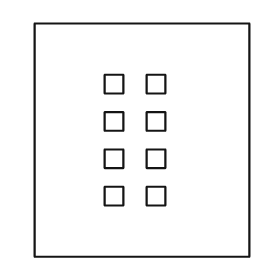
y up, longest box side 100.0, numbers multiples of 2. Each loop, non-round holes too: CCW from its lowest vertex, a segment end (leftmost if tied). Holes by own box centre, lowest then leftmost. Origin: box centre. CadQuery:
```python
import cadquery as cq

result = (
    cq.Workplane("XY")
    .moveTo(-46.0, -50.0)
    .lineTo(46.0, -50.0)
    .lineTo(46.0, 50.0)
    .lineTo(-46.0, 50.0)
    .close()
    .moveTo(-16.0, -28.0)
    .lineTo(-8.0, -28.0)
    .lineTo(-8.0, -20.0)
    .lineTo(-16.0, -20.0)
    .close()
    .moveTo(2.0, -28.0)
    .lineTo(10.0, -28.0)
    .lineTo(10.0, -20.0)
    .lineTo(2.0, -20.0)
    .close()
    .moveTo(-16.0, -12.0)
    .lineTo(-8.0, -12.0)
    .lineTo(-8.0, -4.0)
    .lineTo(-16.0, -4.0)
    .close()
    .moveTo(2.0, -12.0)
    .lineTo(10.0, -12.0)
    .lineTo(10.0, -4.0)
    .lineTo(2.0, -4.0)
    .close()
    .moveTo(-16.0, 4.0)
    .lineTo(-8.0, 4.0)
    .lineTo(-8.0, 12.0)
    .lineTo(-16.0, 12.0)
    .close()
    .moveTo(2.0, 4.0)
    .lineTo(10.0, 4.0)
    .lineTo(10.0, 12.0)
    .lineTo(2.0, 12.0)
    .close()
    .moveTo(-16.0, 20.0)
    .lineTo(-8.0, 20.0)
    .lineTo(-8.0, 28.0)
    .lineTo(-16.0, 28.0)
    .close()
    .moveTo(2.0, 20.0)
    .lineTo(10.0, 20.0)
    .lineTo(10.0, 28.0)
    .lineTo(2.0, 28.0)
    .close()
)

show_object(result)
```